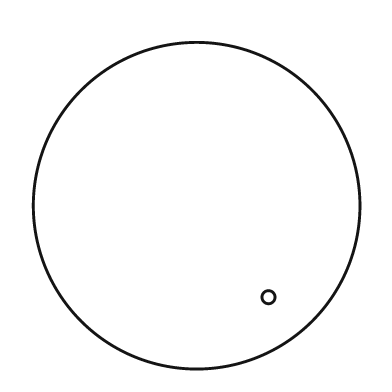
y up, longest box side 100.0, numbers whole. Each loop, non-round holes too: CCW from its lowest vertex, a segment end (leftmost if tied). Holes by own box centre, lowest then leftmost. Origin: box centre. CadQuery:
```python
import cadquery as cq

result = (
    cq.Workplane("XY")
    .moveTo(0.0, 0.0)
    .circle(50.0)
    .moveTo(22.0, -28.0)
    .circle(2.0)
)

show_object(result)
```